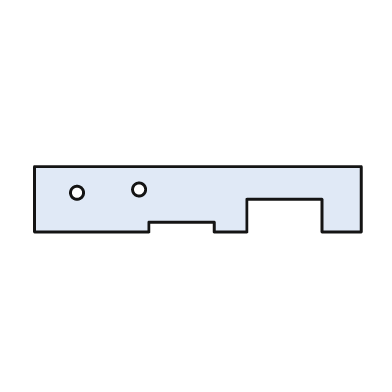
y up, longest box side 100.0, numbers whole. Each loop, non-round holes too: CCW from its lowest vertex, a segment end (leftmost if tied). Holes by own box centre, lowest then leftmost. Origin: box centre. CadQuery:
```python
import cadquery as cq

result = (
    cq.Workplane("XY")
    .moveTo(-50.0, -10.0)
    .lineTo(-15.0, -10.0)
    .lineTo(-15.0, -7.0)
    .lineTo(5.0, -7.0)
    .lineTo(5.0, -10.0)
    .lineTo(15.0, -10.0)
    .lineTo(15.0, 0.0)
    .lineTo(38.0, 0.0)
    .lineTo(38.0, -10.0)
    .lineTo(50.0, -10.0)
    .lineTo(50.0, 10.0)
    .lineTo(-50.0, 10.0)
    .close()
    .moveTo(-37.0, 2.0)
    .circle(2.0)
    .moveTo(-18.0, 3.0)
    .circle(2.0)
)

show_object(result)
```